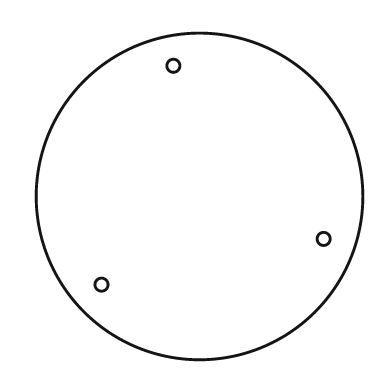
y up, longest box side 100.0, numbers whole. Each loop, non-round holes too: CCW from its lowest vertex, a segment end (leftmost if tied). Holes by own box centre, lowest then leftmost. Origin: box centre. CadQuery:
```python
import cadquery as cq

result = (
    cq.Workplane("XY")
    .moveTo(0.0, 0.0)
    .circle(50.0)
    .moveTo(-30.0, -27.0)
    .circle(2.0)
    .moveTo(38.0, -13.0)
    .circle(2.0)
    .moveTo(-8.0, 40.0)
    .circle(2.0)
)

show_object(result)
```